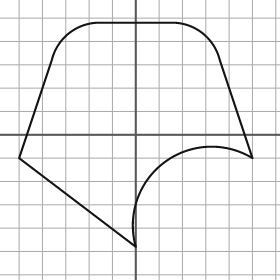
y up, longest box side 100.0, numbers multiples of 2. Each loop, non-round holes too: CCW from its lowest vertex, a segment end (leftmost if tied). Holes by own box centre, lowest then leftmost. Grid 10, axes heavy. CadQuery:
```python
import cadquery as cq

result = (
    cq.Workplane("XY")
    .moveTo(0.0, -48.0)
    .threePointArc((12.0, -12.0), (50.0, -10.0))
    .lineTo(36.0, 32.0)
    .threePointArc((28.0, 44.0), (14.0, 48.0))
    .lineTo(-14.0, 48.0)
    .threePointArc((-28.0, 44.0), (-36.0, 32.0))
    .lineTo(-50.0, -10.0)
    .close()
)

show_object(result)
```